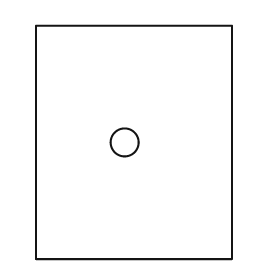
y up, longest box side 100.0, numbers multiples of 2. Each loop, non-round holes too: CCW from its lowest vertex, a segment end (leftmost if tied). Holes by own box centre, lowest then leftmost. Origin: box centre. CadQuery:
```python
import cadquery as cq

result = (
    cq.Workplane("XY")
    .moveTo(-42.0, -50.0)
    .lineTo(42.0, -50.0)
    .lineTo(42.0, 50.0)
    .lineTo(-42.0, 50.0)
    .close()
    .moveTo(-4.0, 0.0)
    .circle(6.0)
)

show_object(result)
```